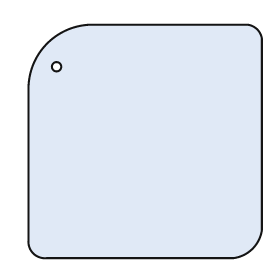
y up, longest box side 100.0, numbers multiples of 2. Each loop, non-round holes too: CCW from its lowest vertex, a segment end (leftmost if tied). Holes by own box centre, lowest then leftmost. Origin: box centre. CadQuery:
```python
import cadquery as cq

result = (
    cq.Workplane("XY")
    .moveTo(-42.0, -50.0)
    .lineTo(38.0, -50.0)
    .threePointArc((46.0, -46.0), (50.0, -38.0))
    .lineTo(50.0, 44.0)
    .threePointArc((48.0, 48.0), (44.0, 50.0))
    .lineTo(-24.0, 50.0)
    .threePointArc((-42.0, 42.0), (-50.0, 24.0))
    .lineTo(-50.0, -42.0)
    .threePointArc((-48.0, -48.0), (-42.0, -50.0))
    .close()
    .moveTo(-38.0, 32.0)
    .circle(2.0)
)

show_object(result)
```